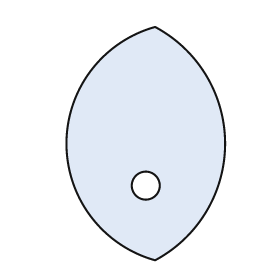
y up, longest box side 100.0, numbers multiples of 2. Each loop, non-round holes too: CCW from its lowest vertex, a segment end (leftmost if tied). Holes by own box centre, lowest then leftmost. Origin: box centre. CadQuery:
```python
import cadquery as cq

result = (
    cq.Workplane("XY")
    .moveTo(4.0, -50.0)
    .threePointArc((34.0, 0.0), (4.0, 50.0))
    .threePointArc((-34.0, 0.0), (4.0, -50.0))
    .close()
    .moveTo(0.0, -18.0)
    .circle(6.0)
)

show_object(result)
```